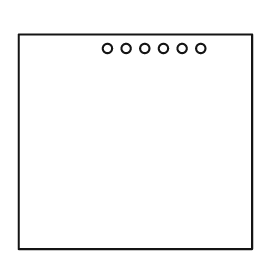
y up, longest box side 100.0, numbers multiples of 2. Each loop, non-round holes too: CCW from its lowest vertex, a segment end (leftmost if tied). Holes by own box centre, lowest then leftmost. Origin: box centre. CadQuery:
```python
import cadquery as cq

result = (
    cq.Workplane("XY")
    .moveTo(-50.0, -46.0)
    .lineTo(50.0, -46.0)
    .lineTo(50.0, 46.0)
    .lineTo(-50.0, 46.0)
    .close()
    .moveTo(-12.0, 40.0)
    .circle(2.0)
    .moveTo(-4.0, 40.0)
    .circle(2.0)
    .moveTo(4.0, 40.0)
    .circle(2.0)
    .moveTo(12.0, 40.0)
    .circle(2.0)
    .moveTo(20.0, 40.0)
    .circle(2.0)
    .moveTo(28.0, 40.0)
    .circle(2.0)
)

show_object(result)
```